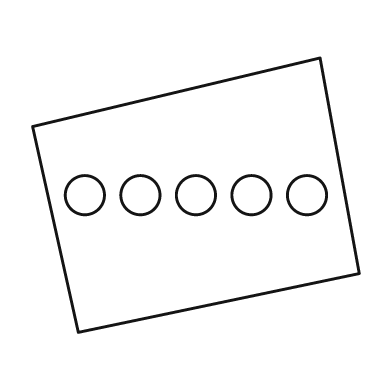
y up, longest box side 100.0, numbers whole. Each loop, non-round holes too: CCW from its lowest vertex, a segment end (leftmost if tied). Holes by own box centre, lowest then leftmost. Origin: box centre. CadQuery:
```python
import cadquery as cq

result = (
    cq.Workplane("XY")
    .moveTo(-36.0, -42.0)
    .lineTo(50.0, -24.0)
    .lineTo(38.0, 42.0)
    .lineTo(-50.0, 21.0)
    .close()
    .moveTo(-34.0, 0.0)
    .circle(6.0)
    .moveTo(-17.0, 0.0)
    .circle(6.0)
    .moveTo(0.0, 0.0)
    .circle(6.0)
    .moveTo(17.0, 0.0)
    .circle(6.0)
    .moveTo(34.0, 0.0)
    .circle(6.0)
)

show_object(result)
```